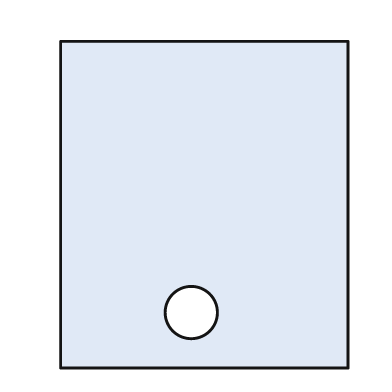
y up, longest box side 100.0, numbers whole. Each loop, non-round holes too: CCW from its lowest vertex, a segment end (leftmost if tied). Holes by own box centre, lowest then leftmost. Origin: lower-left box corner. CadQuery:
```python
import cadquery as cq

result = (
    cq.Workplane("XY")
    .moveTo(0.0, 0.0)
    .lineTo(88.0, 0.0)
    .lineTo(88.0, 100.0)
    .lineTo(0.0, 100.0)
    .close()
    .moveTo(40.0, 17.0)
    .circle(8.0)
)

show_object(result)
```